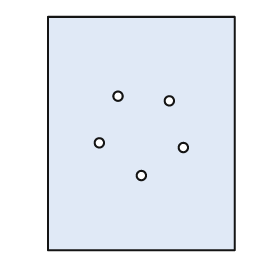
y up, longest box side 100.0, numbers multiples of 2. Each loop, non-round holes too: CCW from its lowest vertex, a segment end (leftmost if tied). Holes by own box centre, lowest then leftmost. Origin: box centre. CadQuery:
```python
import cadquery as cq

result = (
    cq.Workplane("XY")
    .moveTo(-40.0, -50.0)
    .lineTo(40.0, -50.0)
    .lineTo(40.0, 50.0)
    .lineTo(-40.0, 50.0)
    .close()
    .moveTo(0.0, -18.0)
    .circle(2.0)
    .moveTo(18.0, -6.0)
    .circle(2.0)
    .moveTo(-18.0, -4.0)
    .circle(2.0)
    .moveTo(12.0, 14.0)
    .circle(2.0)
    .moveTo(-10.0, 16.0)
    .circle(2.0)
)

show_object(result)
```